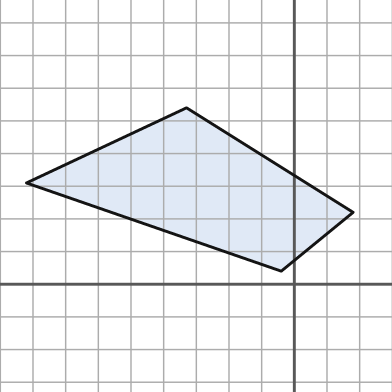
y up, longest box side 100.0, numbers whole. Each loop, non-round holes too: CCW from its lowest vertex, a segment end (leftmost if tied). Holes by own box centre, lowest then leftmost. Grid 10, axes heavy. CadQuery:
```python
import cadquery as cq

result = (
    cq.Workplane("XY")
    .moveTo(-4.0, 4.0)
    .lineTo(18.0, 22.0)
    .lineTo(-33.0, 54.0)
    .lineTo(-82.0, 31.0)
    .close()
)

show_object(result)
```